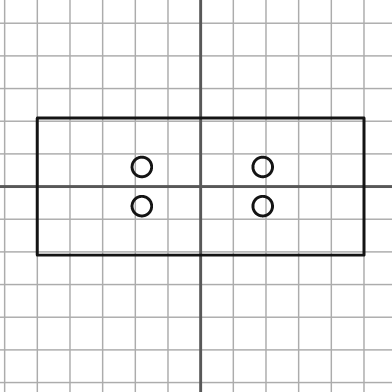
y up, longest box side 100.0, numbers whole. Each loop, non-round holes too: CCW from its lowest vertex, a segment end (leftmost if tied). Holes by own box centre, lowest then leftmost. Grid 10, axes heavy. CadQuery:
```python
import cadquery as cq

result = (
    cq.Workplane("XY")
    .moveTo(-50.0, -21.0)
    .lineTo(50.0, -21.0)
    .lineTo(50.0, 21.0)
    .lineTo(-50.0, 21.0)
    .close()
    .moveTo(-18.0, -6.0)
    .circle(3.0)
    .moveTo(19.0, -6.0)
    .circle(3.0)
    .moveTo(-18.0, 6.0)
    .circle(3.0)
    .moveTo(19.0, 6.0)
    .circle(3.0)
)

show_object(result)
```